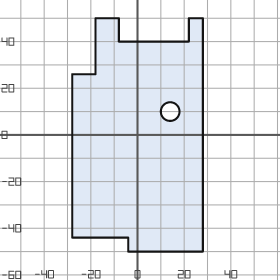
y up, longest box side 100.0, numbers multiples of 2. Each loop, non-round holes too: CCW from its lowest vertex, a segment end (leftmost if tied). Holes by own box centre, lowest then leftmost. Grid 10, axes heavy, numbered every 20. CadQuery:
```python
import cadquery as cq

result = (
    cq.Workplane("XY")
    .moveTo(-4.0, -50.0)
    .lineTo(28.0, -50.0)
    .lineTo(28.0, 50.0)
    .lineTo(22.0, 50.0)
    .lineTo(22.0, 40.0)
    .lineTo(-8.0, 40.0)
    .lineTo(-8.0, 50.0)
    .lineTo(-18.0, 50.0)
    .lineTo(-18.0, 26.0)
    .lineTo(-28.0, 26.0)
    .lineTo(-28.0, -44.0)
    .lineTo(-4.0, -44.0)
    .close()
    .moveTo(14.0, 10.0)
    .circle(4.0)
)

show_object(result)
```